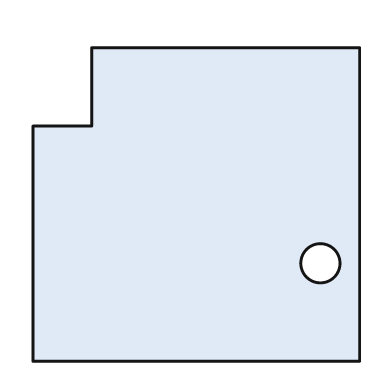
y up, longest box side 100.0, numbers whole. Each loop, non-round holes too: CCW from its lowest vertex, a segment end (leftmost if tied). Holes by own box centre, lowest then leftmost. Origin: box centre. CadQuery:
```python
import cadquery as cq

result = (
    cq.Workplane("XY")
    .moveTo(-50.0, -48.0)
    .lineTo(50.0, -48.0)
    .lineTo(50.0, 48.0)
    .lineTo(-32.0, 48.0)
    .lineTo(-32.0, 24.0)
    .lineTo(-50.0, 24.0)
    .close()
    .moveTo(38.0, -18.0)
    .circle(6.0)
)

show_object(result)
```